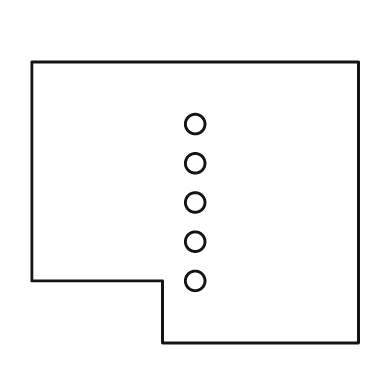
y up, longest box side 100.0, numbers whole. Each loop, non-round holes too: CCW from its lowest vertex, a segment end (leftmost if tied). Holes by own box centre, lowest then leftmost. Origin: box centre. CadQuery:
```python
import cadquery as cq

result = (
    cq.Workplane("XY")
    .moveTo(-10.0, -43.0)
    .lineTo(50.0, -43.0)
    .lineTo(50.0, 43.0)
    .lineTo(-50.0, 43.0)
    .lineTo(-50.0, -24.0)
    .lineTo(-10.0, -24.0)
    .close()
    .moveTo(0.0, -24.0)
    .circle(3.0)
    .moveTo(0.0, -12.0)
    .circle(3.0)
    .moveTo(0.0, 0.0)
    .circle(3.0)
    .moveTo(0.0, 12.0)
    .circle(3.0)
    .moveTo(0.0, 24.0)
    .circle(3.0)
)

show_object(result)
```